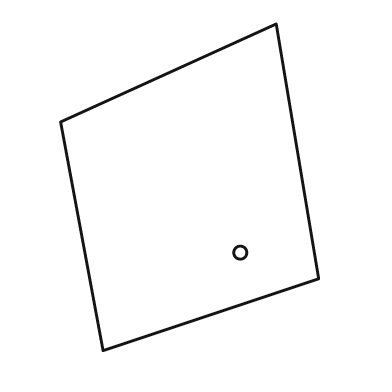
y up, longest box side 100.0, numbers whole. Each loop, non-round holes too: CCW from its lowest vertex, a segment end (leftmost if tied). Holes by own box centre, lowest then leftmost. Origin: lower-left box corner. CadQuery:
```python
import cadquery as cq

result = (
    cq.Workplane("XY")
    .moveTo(13.0, 0.0)
    .lineTo(79.0, 22.0)
    .lineTo(66.0, 100.0)
    .lineTo(0.0, 70.0)
    .close()
    .moveTo(55.0, 30.0)
    .circle(2.0)
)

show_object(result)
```